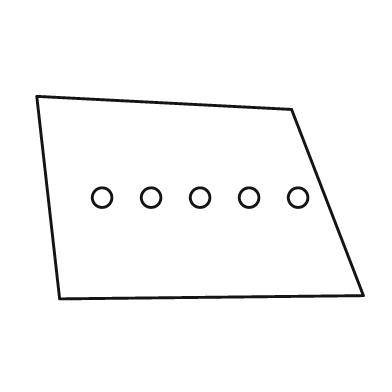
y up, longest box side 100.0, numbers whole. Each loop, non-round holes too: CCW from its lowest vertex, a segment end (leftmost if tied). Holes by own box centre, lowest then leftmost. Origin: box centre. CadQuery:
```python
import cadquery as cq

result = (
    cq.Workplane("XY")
    .moveTo(-43.0, -31.0)
    .lineTo(50.0, -30.0)
    .lineTo(28.0, 27.0)
    .lineTo(-50.0, 31.0)
    .close()
    .moveTo(-30.0, 0.0)
    .circle(3.0)
    .moveTo(-15.0, 0.0)
    .circle(3.0)
    .moveTo(0.0, 0.0)
    .circle(3.0)
    .moveTo(15.0, 0.0)
    .circle(3.0)
    .moveTo(30.0, 0.0)
    .circle(3.0)
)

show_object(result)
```